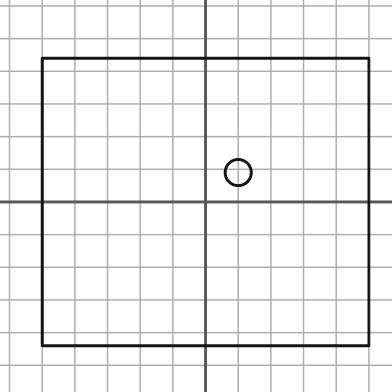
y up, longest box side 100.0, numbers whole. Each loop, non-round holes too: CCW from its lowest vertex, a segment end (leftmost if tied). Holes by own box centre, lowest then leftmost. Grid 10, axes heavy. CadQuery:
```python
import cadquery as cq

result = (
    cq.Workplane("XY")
    .moveTo(-50.0, -44.0)
    .lineTo(50.0, -44.0)
    .lineTo(50.0, 44.0)
    .lineTo(-50.0, 44.0)
    .close()
    .moveTo(10.0, 9.0)
    .circle(4.0)
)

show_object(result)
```